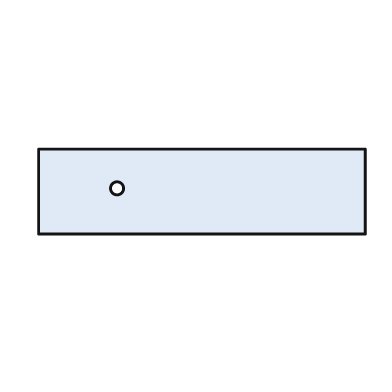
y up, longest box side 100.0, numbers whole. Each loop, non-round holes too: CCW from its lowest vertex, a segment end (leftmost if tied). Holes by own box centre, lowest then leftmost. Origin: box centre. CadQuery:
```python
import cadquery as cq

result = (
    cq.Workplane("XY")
    .moveTo(-50.0, -13.0)
    .lineTo(50.0, -13.0)
    .lineTo(50.0, 13.0)
    .lineTo(-50.0, 13.0)
    .close()
    .moveTo(-26.0, 1.0)
    .circle(2.0)
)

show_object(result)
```